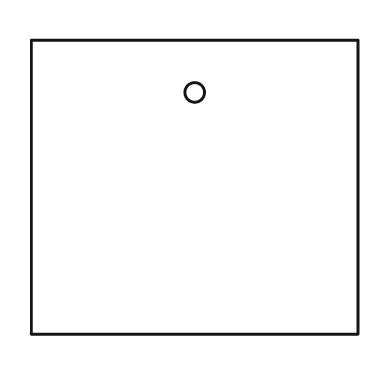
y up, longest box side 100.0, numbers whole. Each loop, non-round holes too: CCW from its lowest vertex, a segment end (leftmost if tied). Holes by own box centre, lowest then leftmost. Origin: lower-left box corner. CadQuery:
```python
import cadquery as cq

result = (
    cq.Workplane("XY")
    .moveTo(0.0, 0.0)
    .lineTo(100.0, 0.0)
    .lineTo(100.0, 90.0)
    .lineTo(0.0, 90.0)
    .close()
    .moveTo(50.0, 74.0)
    .circle(3.0)
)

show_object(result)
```